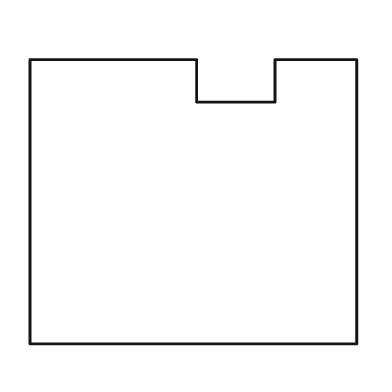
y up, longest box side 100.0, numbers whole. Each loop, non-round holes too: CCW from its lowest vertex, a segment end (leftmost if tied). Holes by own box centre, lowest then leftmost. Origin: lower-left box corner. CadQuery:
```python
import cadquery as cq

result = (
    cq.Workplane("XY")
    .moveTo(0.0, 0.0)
    .lineTo(100.0, 0.0)
    .lineTo(100.0, 87.0)
    .lineTo(75.0, 87.0)
    .lineTo(75.0, 74.0)
    .lineTo(51.0, 74.0)
    .lineTo(51.0, 87.0)
    .lineTo(0.0, 87.0)
    .close()
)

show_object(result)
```